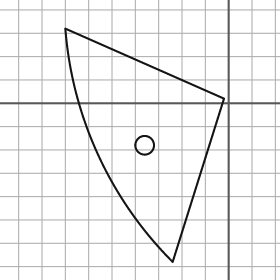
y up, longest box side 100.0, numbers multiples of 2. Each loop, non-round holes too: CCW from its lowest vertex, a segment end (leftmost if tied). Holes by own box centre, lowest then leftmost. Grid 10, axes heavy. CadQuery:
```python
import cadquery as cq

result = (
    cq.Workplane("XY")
    .moveTo(-24.0, -68.0)
    .lineTo(-2.0, 2.0)
    .lineTo(-70.0, 32.0)
    .threePointArc((-56.0, -22.0), (-24.0, -68.0))
    .close()
    .moveTo(-36.0, -18.0)
    .circle(4.0)
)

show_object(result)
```